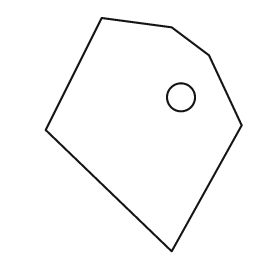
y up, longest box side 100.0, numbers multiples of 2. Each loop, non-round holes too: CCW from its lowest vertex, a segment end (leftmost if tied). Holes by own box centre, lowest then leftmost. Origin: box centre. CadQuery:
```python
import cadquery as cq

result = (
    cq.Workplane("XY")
    .moveTo(12.0, -50.0)
    .lineTo(42.0, 4.0)
    .lineTo(28.0, 34.0)
    .lineTo(12.0, 46.0)
    .lineTo(-18.0, 50.0)
    .lineTo(-42.0, 2.0)
    .close()
    .moveTo(16.0, 16.0)
    .circle(6.0)
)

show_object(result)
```